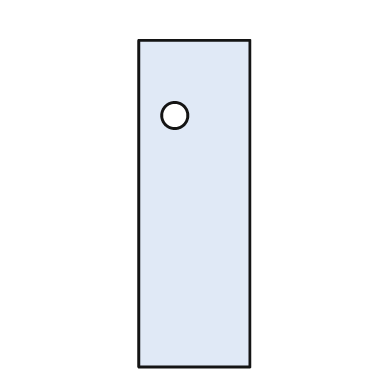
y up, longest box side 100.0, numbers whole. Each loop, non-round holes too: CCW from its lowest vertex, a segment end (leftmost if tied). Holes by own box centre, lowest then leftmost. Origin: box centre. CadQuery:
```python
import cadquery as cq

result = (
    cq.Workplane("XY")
    .moveTo(-17.0, -50.0)
    .lineTo(17.0, -50.0)
    .lineTo(17.0, 50.0)
    .lineTo(-17.0, 50.0)
    .close()
    .moveTo(-6.0, 27.0)
    .circle(4.0)
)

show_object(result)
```